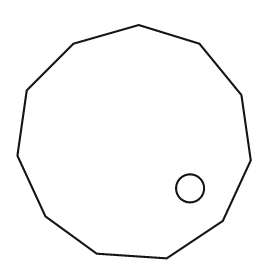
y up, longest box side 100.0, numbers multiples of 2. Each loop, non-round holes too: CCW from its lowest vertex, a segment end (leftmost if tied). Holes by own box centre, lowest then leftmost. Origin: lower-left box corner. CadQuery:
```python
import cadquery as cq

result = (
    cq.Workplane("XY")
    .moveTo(64.0, 0.0)
    .lineTo(88.0, 16.0)
    .lineTo(100.0, 42.0)
    .lineTo(96.0, 70.0)
    .lineTo(78.0, 92.0)
    .lineTo(52.0, 100.0)
    .lineTo(24.0, 92.0)
    .lineTo(4.0, 72.0)
    .lineTo(0.0, 44.0)
    .lineTo(12.0, 18.0)
    .lineTo(34.0, 2.0)
    .close()
    .moveTo(74.0, 30.0)
    .circle(6.0)
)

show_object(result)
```